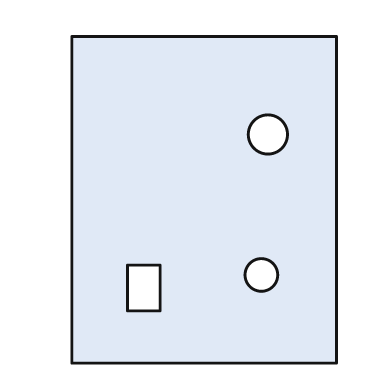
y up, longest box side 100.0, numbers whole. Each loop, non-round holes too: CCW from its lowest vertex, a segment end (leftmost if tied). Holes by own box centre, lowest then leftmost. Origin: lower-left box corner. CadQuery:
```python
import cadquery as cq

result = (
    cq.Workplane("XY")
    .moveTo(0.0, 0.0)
    .lineTo(81.0, 0.0)
    .lineTo(81.0, 100.0)
    .lineTo(0.0, 100.0)
    .close()
    .moveTo(17.0, 16.0)
    .lineTo(27.0, 16.0)
    .lineTo(27.0, 30.0)
    .lineTo(17.0, 30.0)
    .close()
    .moveTo(58.0, 27.0)
    .circle(5.0)
    .moveTo(60.0, 70.0)
    .circle(6.0)
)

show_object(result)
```